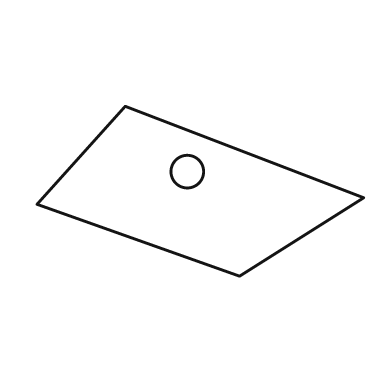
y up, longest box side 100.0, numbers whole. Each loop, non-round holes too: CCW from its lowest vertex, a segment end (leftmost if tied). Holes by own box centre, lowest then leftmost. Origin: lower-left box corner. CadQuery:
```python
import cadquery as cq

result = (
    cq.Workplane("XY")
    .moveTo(62.0, 0.0)
    .lineTo(100.0, 24.0)
    .lineTo(27.0, 52.0)
    .lineTo(0.0, 22.0)
    .close()
    .moveTo(46.0, 32.0)
    .circle(5.0)
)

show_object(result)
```